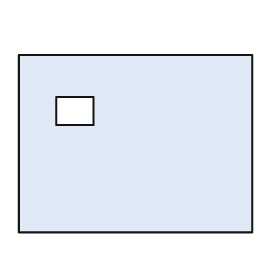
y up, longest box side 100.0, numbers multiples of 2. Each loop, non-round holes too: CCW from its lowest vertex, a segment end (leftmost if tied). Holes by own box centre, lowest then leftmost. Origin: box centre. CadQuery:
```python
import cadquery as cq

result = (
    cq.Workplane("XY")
    .moveTo(-50.0, -38.0)
    .lineTo(50.0, -38.0)
    .lineTo(50.0, 38.0)
    .lineTo(-50.0, 38.0)
    .close()
    .moveTo(-34.0, 8.0)
    .lineTo(-18.0, 8.0)
    .lineTo(-18.0, 20.0)
    .lineTo(-34.0, 20.0)
    .close()
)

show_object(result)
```